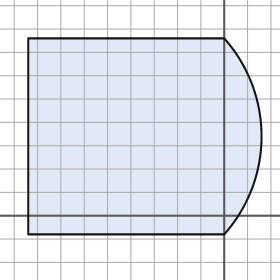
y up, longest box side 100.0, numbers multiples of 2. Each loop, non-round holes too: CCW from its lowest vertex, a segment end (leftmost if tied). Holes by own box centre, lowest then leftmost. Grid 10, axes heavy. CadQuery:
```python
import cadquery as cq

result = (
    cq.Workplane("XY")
    .moveTo(-84.0, -8.0)
    .lineTo(0.0, -8.0)
    .threePointArc((16.0, 34.0), (0.0, 76.0))
    .lineTo(-84.0, 76.0)
    .close()
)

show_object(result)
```